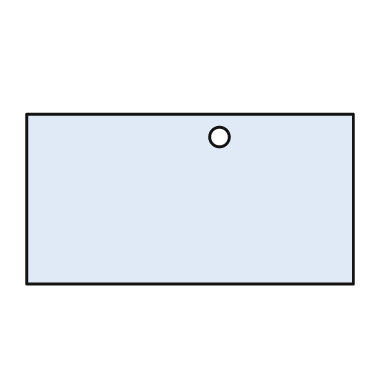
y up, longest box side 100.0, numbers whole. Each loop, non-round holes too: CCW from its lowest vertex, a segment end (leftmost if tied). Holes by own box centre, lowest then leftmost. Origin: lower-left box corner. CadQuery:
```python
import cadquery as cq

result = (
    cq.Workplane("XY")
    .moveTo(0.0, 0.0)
    .lineTo(100.0, 0.0)
    .lineTo(100.0, 52.0)
    .lineTo(0.0, 52.0)
    .close()
    .moveTo(59.0, 45.0)
    .circle(3.0)
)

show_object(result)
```